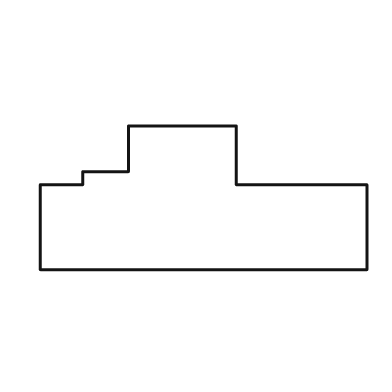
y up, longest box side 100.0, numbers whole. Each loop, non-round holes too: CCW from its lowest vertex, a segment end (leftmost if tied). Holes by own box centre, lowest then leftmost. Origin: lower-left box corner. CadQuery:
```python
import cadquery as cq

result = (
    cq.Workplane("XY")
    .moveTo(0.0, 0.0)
    .lineTo(100.0, 0.0)
    .lineTo(100.0, 26.0)
    .lineTo(60.0, 26.0)
    .lineTo(60.0, 44.0)
    .lineTo(27.0, 44.0)
    .lineTo(27.0, 30.0)
    .lineTo(13.0, 30.0)
    .lineTo(13.0, 26.0)
    .lineTo(0.0, 26.0)
    .close()
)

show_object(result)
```